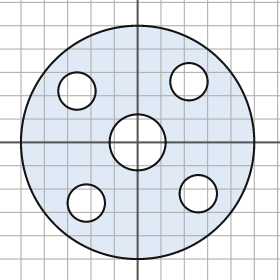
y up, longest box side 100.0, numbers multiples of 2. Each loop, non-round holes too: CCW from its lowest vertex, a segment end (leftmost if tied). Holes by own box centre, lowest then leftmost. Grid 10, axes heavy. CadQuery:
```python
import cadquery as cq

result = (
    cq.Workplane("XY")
    .moveTo(0.0, 0.0)
    .circle(50.0)
    .moveTo(-22.0, -26.0)
    .circle(8.0)
    .moveTo(26.0, -22.0)
    .circle(8.0)
    .moveTo(0.0, 0.0)
    .circle(12.0)
    .moveTo(-26.0, 22.0)
    .circle(8.0)
    .moveTo(22.0, 26.0)
    .circle(8.0)
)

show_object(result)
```